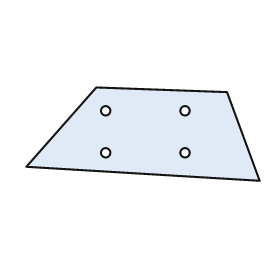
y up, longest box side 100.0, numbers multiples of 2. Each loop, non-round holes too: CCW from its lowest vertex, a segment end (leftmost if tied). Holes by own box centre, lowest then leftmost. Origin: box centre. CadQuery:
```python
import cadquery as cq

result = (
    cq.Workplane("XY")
    .moveTo(50.0, -20.0)
    .lineTo(36.0, 18.0)
    .lineTo(-20.0, 20.0)
    .lineTo(-50.0, -14.0)
    .close()
    .moveTo(-16.0, -8.0)
    .circle(2.0)
    .moveTo(18.0, -8.0)
    .circle(2.0)
    .moveTo(-16.0, 10.0)
    .circle(2.0)
    .moveTo(18.0, 10.0)
    .circle(2.0)
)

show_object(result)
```